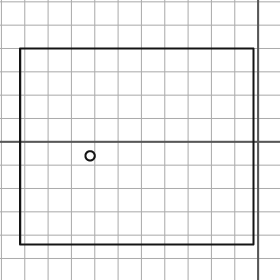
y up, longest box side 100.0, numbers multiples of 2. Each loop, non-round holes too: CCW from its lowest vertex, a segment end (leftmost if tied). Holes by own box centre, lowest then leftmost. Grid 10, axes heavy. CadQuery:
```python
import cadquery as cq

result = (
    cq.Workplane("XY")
    .moveTo(-102.0, -44.0)
    .lineTo(-2.0, -44.0)
    .lineTo(-2.0, 40.0)
    .lineTo(-102.0, 40.0)
    .close()
    .moveTo(-72.0, -6.0)
    .circle(2.0)
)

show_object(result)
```